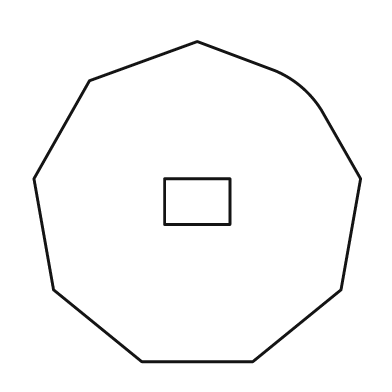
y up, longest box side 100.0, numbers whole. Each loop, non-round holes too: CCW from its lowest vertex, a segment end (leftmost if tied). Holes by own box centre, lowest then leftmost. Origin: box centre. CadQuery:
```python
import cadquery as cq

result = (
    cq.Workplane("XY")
    .moveTo(-17.0, -49.0)
    .lineTo(17.0, -49.0)
    .lineTo(44.0, -27.0)
    .lineTo(50.0, 7.0)
    .lineTo(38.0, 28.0)
    .threePointArc((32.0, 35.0), (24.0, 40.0))
    .lineTo(0.0, 49.0)
    .lineTo(-33.0, 37.0)
    .lineTo(-50.0, 7.0)
    .lineTo(-44.0, -27.0)
    .close()
    .moveTo(-10.0, -7.0)
    .lineTo(10.0, -7.0)
    .lineTo(10.0, 7.0)
    .lineTo(-10.0, 7.0)
    .close()
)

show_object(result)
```